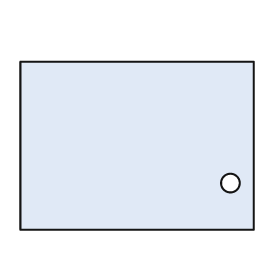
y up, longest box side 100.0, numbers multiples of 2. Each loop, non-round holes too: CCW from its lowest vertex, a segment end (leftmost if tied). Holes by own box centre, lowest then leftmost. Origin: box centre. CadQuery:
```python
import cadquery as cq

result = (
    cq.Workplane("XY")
    .moveTo(-50.0, -36.0)
    .lineTo(50.0, -36.0)
    .lineTo(50.0, 36.0)
    .lineTo(-50.0, 36.0)
    .close()
    .moveTo(40.0, -16.0)
    .circle(4.0)
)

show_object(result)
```